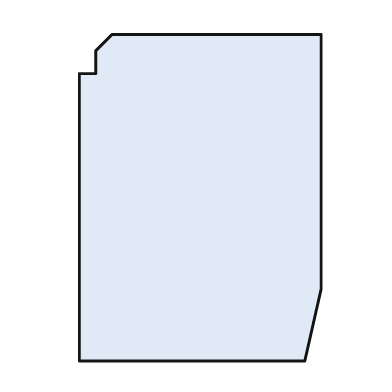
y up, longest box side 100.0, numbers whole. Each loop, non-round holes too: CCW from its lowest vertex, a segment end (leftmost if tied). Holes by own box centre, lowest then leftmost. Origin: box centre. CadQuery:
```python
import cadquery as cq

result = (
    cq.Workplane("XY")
    .moveTo(-37.0, -50.0)
    .lineTo(32.0, -50.0)
    .lineTo(37.0, -28.0)
    .lineTo(37.0, 50.0)
    .lineTo(-27.0, 50.0)
    .lineTo(-32.0, 45.0)
    .lineTo(-32.0, 38.0)
    .lineTo(-37.0, 38.0)
    .close()
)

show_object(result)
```